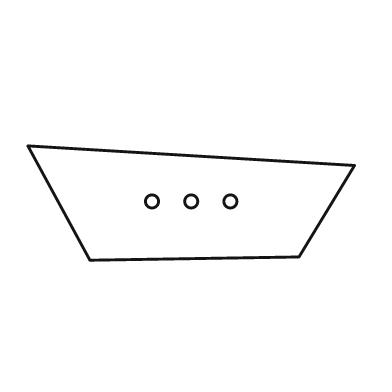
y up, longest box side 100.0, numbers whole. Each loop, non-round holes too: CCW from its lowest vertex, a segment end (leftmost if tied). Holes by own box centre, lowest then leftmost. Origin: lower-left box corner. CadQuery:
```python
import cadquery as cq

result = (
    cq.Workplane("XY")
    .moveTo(19.0, 0.0)
    .lineTo(83.0, 1.0)
    .lineTo(100.0, 29.0)
    .lineTo(0.0, 35.0)
    .close()
    .moveTo(38.0, 18.0)
    .circle(2.0)
    .moveTo(50.0, 18.0)
    .circle(2.0)
    .moveTo(62.0, 18.0)
    .circle(2.0)
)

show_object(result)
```